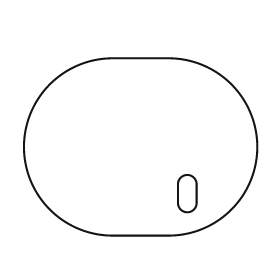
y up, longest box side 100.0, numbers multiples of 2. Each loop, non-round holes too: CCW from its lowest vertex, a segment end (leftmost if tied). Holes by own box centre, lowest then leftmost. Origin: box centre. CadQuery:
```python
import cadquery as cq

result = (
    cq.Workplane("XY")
    .moveTo(-12.0, -38.0)
    .lineTo(12.0, -38.0)
    .threePointArc((50.0, 0.0), (12.0, 38.0))
    .lineTo(-12.0, 38.0)
    .threePointArc((-50.0, 0.0), (-12.0, -38.0))
    .close()
    .moveTo(16.0, -24.0)
    .threePointArc((20.0, -28.0), (24.0, -24.0))
    .lineTo(24.0, -16.0)
    .threePointArc((20.0, -12.0), (16.0, -16.0))
    .close()
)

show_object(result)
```